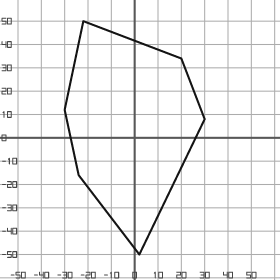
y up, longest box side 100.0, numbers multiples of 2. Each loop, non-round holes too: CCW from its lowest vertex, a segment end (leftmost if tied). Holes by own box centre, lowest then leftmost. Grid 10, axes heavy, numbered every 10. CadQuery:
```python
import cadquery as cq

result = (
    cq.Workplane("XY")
    .moveTo(2.0, -50.0)
    .lineTo(30.0, 8.0)
    .lineTo(20.0, 34.0)
    .lineTo(-22.0, 50.0)
    .lineTo(-30.0, 12.0)
    .lineTo(-24.0, -16.0)
    .close()
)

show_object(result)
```